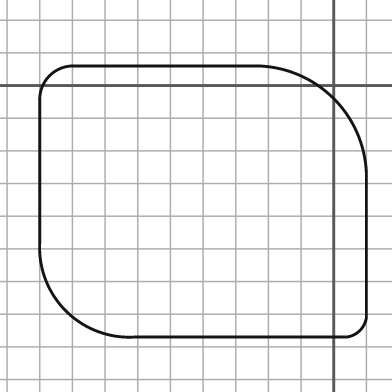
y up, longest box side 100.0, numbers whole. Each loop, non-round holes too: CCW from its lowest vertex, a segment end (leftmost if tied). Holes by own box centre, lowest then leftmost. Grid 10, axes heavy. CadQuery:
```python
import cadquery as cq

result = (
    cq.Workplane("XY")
    .moveTo(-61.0, -77.0)
    .lineTo(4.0, -77.0)
    .threePointArc((8.0, -75.0), (10.0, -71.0))
    .lineTo(10.0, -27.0)
    .threePointArc((0.0, -4.0), (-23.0, 6.0))
    .lineTo(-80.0, 6.0)
    .threePointArc((-87.0, 3.0), (-90.0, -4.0))
    .lineTo(-90.0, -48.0)
    .threePointArc((-82.0, -69.0), (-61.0, -77.0))
    .close()
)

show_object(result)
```